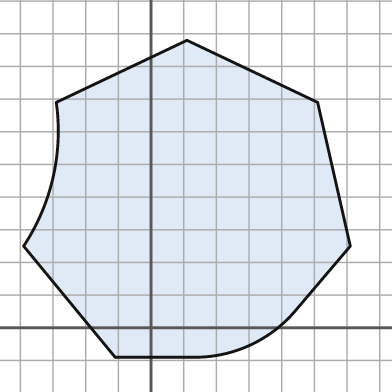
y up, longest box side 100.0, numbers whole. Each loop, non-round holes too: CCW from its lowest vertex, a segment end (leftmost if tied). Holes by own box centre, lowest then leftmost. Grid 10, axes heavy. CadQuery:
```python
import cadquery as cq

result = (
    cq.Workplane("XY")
    .moveTo(-11.0, -9.0)
    .lineTo(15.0, -9.0)
    .threePointArc((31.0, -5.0), (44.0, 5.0))
    .lineTo(61.0, 25.0)
    .lineTo(51.0, 69.0)
    .lineTo(11.0, 88.0)
    .lineTo(-29.0, 69.0)
    .threePointArc((-30.0, 46.0), (-39.0, 25.0))
    .close()
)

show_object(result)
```